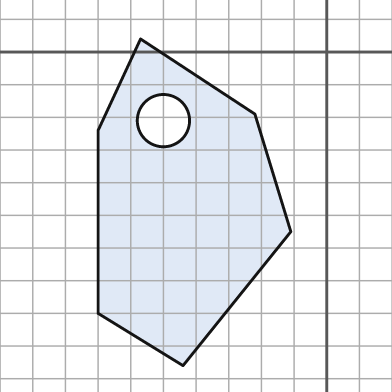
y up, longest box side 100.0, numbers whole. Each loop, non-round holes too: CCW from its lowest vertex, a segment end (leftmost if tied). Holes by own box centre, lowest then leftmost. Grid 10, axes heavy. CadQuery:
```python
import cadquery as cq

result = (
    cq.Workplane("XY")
    .moveTo(-44.0, -96.0)
    .lineTo(-11.0, -55.0)
    .lineTo(-22.0, -19.0)
    .lineTo(-57.0, 4.0)
    .lineTo(-70.0, -24.0)
    .lineTo(-70.0, -80.0)
    .close()
    .moveTo(-50.0, -21.0)
    .circle(8.0)
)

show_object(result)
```